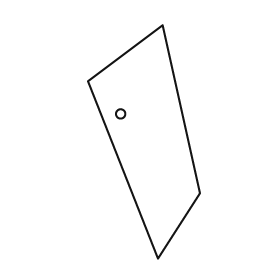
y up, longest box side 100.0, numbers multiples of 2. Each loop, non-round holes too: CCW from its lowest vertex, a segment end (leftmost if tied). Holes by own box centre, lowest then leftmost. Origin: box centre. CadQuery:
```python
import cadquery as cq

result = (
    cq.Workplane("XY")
    .moveTo(6.0, -50.0)
    .lineTo(24.0, -22.0)
    .lineTo(8.0, 50.0)
    .lineTo(-24.0, 26.0)
    .close()
    .moveTo(-10.0, 12.0)
    .circle(2.0)
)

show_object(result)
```